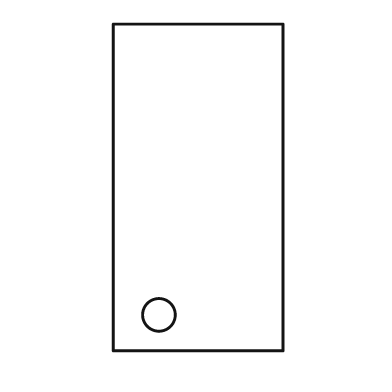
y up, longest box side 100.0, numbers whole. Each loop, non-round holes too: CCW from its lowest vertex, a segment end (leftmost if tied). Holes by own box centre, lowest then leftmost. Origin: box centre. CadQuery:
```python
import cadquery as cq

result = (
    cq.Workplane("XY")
    .moveTo(-26.0, -50.0)
    .lineTo(26.0, -50.0)
    .lineTo(26.0, 50.0)
    .lineTo(-26.0, 50.0)
    .close()
    .moveTo(-12.0, -39.0)
    .circle(5.0)
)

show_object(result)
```